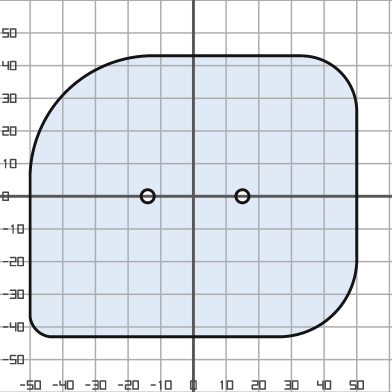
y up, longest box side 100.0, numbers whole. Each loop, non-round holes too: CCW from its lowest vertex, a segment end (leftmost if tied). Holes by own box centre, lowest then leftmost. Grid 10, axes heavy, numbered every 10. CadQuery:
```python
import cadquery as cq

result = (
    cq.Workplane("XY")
    .moveTo(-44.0, -43.0)
    .lineTo(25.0, -43.0)
    .threePointArc((43.0, -36.0), (50.0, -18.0))
    .lineTo(50.0, 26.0)
    .threePointArc((45.0, 38.0), (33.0, 43.0))
    .lineTo(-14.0, 43.0)
    .threePointArc((-39.0, 32.0), (-50.0, 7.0))
    .lineTo(-50.0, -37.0)
    .threePointArc((-48.0, -41.0), (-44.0, -43.0))
    .close()
    .moveTo(-14.0, 0.0)
    .circle(2.0)
    .moveTo(15.0, 0.0)
    .circle(2.0)
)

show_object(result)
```